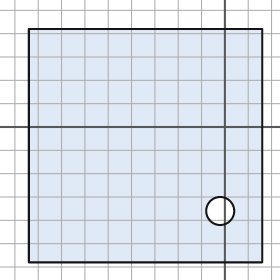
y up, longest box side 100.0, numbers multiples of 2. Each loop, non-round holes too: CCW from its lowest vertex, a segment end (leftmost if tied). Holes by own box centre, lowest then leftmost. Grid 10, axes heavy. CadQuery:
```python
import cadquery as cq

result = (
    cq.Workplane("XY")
    .moveTo(-84.0, -58.0)
    .lineTo(16.0, -58.0)
    .lineTo(16.0, 42.0)
    .lineTo(-84.0, 42.0)
    .close()
    .moveTo(-2.0, -36.0)
    .circle(6.0)
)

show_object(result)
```